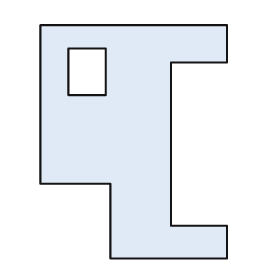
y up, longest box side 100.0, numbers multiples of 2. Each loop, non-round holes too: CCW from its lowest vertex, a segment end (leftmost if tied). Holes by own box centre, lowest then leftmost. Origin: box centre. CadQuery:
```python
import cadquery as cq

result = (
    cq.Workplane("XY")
    .moveTo(-10.0, -50.0)
    .lineTo(40.0, -50.0)
    .lineTo(40.0, -36.0)
    .lineTo(16.0, -36.0)
    .lineTo(16.0, 34.0)
    .lineTo(40.0, 34.0)
    .lineTo(40.0, 50.0)
    .lineTo(-40.0, 50.0)
    .lineTo(-40.0, -18.0)
    .lineTo(-10.0, -18.0)
    .close()
    .moveTo(-28.0, 20.0)
    .lineTo(-12.0, 20.0)
    .lineTo(-12.0, 40.0)
    .lineTo(-28.0, 40.0)
    .close()
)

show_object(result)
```